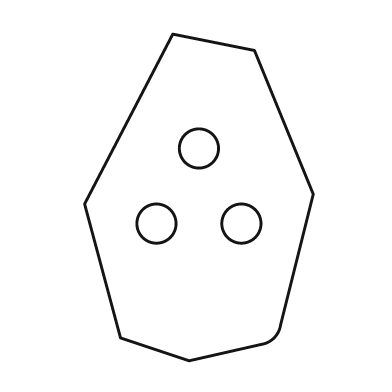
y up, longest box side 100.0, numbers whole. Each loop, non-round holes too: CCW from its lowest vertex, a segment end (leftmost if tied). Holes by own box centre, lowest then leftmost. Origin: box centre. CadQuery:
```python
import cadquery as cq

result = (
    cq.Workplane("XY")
    .moveTo(-3.0, -50.0)
    .lineTo(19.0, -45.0)
    .threePointArc((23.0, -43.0), (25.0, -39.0))
    .lineTo(35.0, 1.0)
    .lineTo(17.0, 45.0)
    .lineTo(-8.0, 50.0)
    .lineTo(-35.0, -2.0)
    .lineTo(-24.0, -43.0)
    .close()
    .moveTo(-13.0, -8.0)
    .circle(6.0)
    .moveTo(13.0, -8.0)
    .circle(6.0)
    .moveTo(0.0, 15.0)
    .circle(6.0)
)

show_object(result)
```